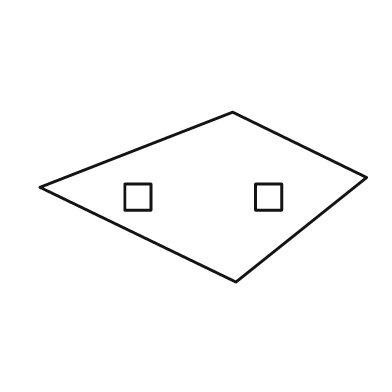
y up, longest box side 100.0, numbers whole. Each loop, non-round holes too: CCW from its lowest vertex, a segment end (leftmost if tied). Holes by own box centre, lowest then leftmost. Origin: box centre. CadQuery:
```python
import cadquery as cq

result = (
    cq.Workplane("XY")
    .moveTo(10.0, -26.0)
    .lineTo(50.0, 6.0)
    .lineTo(9.0, 26.0)
    .lineTo(-50.0, 3.0)
    .close()
    .moveTo(-24.0, -4.0)
    .lineTo(-16.0, -4.0)
    .lineTo(-16.0, 4.0)
    .lineTo(-24.0, 4.0)
    .close()
    .moveTo(16.0, -4.0)
    .lineTo(24.0, -4.0)
    .lineTo(24.0, 4.0)
    .lineTo(16.0, 4.0)
    .close()
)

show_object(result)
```